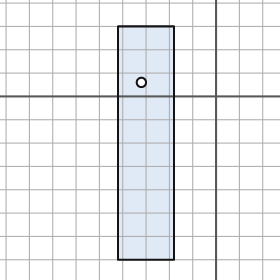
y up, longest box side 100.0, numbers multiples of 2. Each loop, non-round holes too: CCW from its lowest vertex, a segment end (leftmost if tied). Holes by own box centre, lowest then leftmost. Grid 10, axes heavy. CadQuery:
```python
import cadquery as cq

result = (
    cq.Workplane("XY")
    .moveTo(-42.0, -70.0)
    .lineTo(-18.0, -70.0)
    .lineTo(-18.0, 30.0)
    .lineTo(-42.0, 30.0)
    .close()
    .moveTo(-32.0, 6.0)
    .circle(2.0)
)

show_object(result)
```